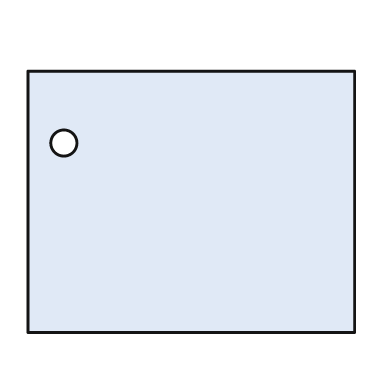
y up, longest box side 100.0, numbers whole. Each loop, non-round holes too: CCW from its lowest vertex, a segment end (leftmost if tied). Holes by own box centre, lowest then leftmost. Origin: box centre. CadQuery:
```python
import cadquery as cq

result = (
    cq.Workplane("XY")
    .moveTo(-50.0, -40.0)
    .lineTo(50.0, -40.0)
    .lineTo(50.0, 40.0)
    .lineTo(-50.0, 40.0)
    .close()
    .moveTo(-39.0, 18.0)
    .circle(4.0)
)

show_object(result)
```